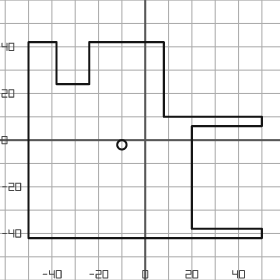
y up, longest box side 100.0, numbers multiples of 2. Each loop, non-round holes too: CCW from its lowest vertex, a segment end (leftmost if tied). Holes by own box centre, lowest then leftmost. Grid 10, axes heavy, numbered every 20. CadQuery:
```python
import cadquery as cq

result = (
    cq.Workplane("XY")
    .moveTo(-50.0, -42.0)
    .lineTo(50.0, -42.0)
    .lineTo(50.0, -38.0)
    .lineTo(20.0, -38.0)
    .lineTo(20.0, 6.0)
    .lineTo(50.0, 6.0)
    .lineTo(50.0, 10.0)
    .lineTo(8.0, 10.0)
    .lineTo(8.0, 42.0)
    .lineTo(-24.0, 42.0)
    .lineTo(-24.0, 24.0)
    .lineTo(-38.0, 24.0)
    .lineTo(-38.0, 42.0)
    .lineTo(-50.0, 42.0)
    .close()
    .moveTo(-10.0, -2.0)
    .circle(2.0)
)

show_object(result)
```